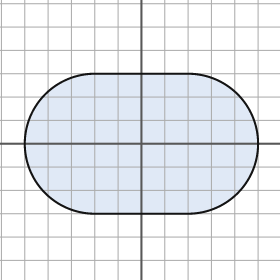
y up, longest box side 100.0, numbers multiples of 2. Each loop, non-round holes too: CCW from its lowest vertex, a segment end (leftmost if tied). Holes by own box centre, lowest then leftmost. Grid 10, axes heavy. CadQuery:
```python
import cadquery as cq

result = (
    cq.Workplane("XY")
    .moveTo(-20.0, -30.0)
    .lineTo(20.0, -30.0)
    .threePointArc((50.0, 0.0), (20.0, 30.0))
    .lineTo(-20.0, 30.0)
    .threePointArc((-50.0, 0.0), (-20.0, -30.0))
    .close()
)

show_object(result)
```